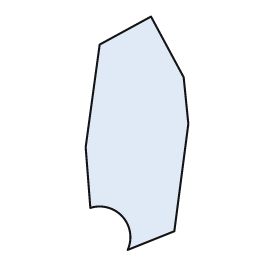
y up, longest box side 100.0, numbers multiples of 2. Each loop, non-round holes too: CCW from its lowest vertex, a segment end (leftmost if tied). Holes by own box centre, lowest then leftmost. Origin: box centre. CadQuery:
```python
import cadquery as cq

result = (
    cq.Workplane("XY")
    .moveTo(-4.0, -50.0)
    .lineTo(16.0, -42.0)
    .lineTo(22.0, 4.0)
    .lineTo(20.0, 24.0)
    .lineTo(6.0, 50.0)
    .lineTo(-16.0, 38.0)
    .lineTo(-22.0, -6.0)
    .lineTo(-20.0, -32.0)
    .threePointArc((-6.0, -36.0), (-4.0, -50.0))
    .close()
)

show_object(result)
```